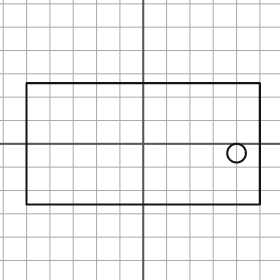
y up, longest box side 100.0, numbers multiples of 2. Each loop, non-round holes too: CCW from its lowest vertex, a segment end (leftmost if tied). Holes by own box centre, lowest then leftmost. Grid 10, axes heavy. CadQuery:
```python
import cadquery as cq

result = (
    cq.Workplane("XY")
    .moveTo(-50.0, -26.0)
    .lineTo(50.0, -26.0)
    .lineTo(50.0, 26.0)
    .lineTo(-50.0, 26.0)
    .close()
    .moveTo(40.0, -4.0)
    .circle(4.0)
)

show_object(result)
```